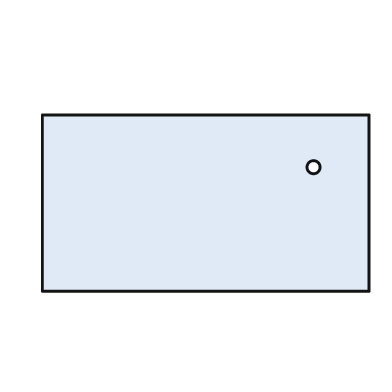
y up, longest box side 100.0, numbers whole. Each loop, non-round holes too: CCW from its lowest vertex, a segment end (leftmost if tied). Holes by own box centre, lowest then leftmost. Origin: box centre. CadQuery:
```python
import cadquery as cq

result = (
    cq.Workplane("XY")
    .moveTo(-50.0, -27.0)
    .lineTo(50.0, -27.0)
    .lineTo(50.0, 27.0)
    .lineTo(-50.0, 27.0)
    .close()
    .moveTo(33.0, 11.0)
    .circle(2.0)
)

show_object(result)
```